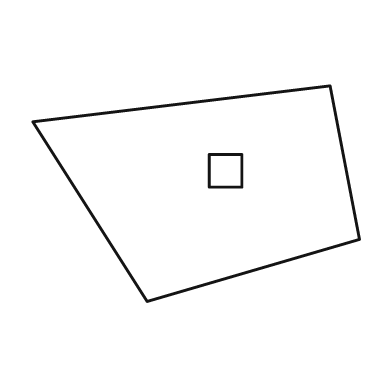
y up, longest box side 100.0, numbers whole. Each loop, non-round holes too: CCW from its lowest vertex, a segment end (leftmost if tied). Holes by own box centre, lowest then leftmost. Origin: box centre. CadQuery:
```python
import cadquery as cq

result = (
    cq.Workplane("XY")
    .moveTo(-15.0, -33.0)
    .lineTo(50.0, -14.0)
    .lineTo(41.0, 33.0)
    .lineTo(-50.0, 22.0)
    .close()
    .moveTo(4.0, 2.0)
    .lineTo(14.0, 2.0)
    .lineTo(14.0, 12.0)
    .lineTo(4.0, 12.0)
    .close()
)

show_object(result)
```